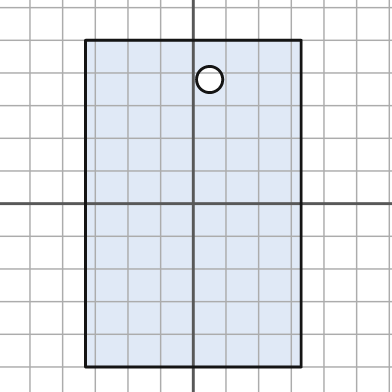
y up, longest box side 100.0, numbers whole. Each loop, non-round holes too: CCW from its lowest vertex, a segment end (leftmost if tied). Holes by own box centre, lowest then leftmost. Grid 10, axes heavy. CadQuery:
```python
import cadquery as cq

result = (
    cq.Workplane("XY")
    .moveTo(-33.0, -50.0)
    .lineTo(33.0, -50.0)
    .lineTo(33.0, 50.0)
    .lineTo(-33.0, 50.0)
    .close()
    .moveTo(5.0, 38.0)
    .circle(4.0)
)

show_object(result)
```